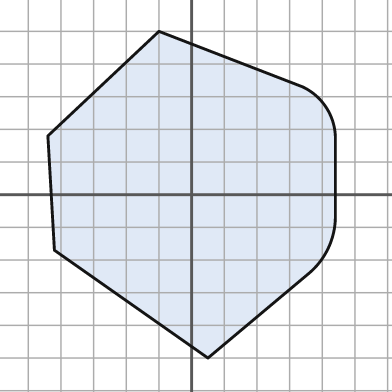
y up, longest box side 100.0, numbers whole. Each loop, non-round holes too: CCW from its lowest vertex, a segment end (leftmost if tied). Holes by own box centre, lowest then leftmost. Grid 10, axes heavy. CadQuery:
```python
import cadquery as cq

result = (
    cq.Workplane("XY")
    .moveTo(5.0, -50.0)
    .lineTo(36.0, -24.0)
    .threePointArc((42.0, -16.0), (44.0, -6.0))
    .lineTo(44.0, 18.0)
    .threePointArc((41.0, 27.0), (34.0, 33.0))
    .lineTo(-10.0, 50.0)
    .lineTo(-44.0, 18.0)
    .lineTo(-42.0, -17.0)
    .close()
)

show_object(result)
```